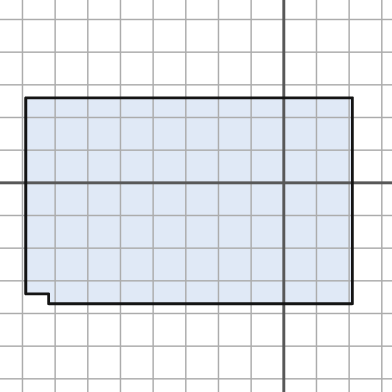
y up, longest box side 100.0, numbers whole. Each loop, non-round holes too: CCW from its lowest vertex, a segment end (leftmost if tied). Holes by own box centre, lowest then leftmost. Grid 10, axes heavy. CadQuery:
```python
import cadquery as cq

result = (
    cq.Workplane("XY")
    .moveTo(-72.0, -37.0)
    .lineTo(21.0, -37.0)
    .lineTo(21.0, 26.0)
    .lineTo(-79.0, 26.0)
    .lineTo(-79.0, -34.0)
    .lineTo(-72.0, -34.0)
    .close()
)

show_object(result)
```